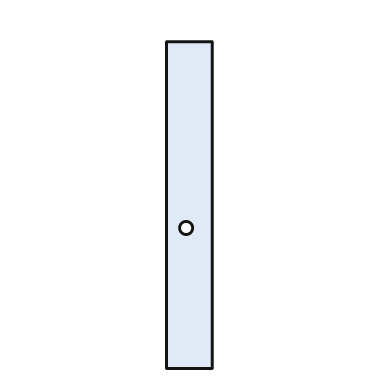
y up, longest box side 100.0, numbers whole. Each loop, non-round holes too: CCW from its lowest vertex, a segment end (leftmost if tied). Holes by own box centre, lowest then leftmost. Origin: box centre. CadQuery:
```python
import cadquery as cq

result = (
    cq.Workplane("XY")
    .moveTo(-7.0, -50.0)
    .lineTo(7.0, -50.0)
    .lineTo(7.0, 50.0)
    .lineTo(-7.0, 50.0)
    .close()
    .moveTo(-1.0, -7.0)
    .circle(2.0)
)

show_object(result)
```